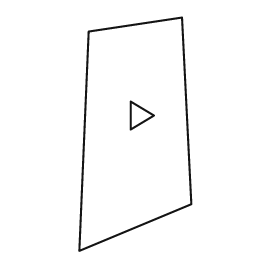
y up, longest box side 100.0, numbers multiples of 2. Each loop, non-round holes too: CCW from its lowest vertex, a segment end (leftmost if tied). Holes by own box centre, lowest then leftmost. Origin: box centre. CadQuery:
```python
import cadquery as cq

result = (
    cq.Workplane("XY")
    .moveTo(-24.0, -50.0)
    .lineTo(24.0, -30.0)
    .lineTo(20.0, 50.0)
    .lineTo(-20.0, 44.0)
    .close()
    .moveTo(-2.0, 2.0)
    .lineTo(8.0, 8.0)
    .lineTo(-2.0, 14.0)
    .close()
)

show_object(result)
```